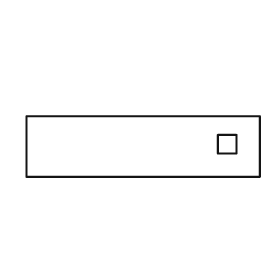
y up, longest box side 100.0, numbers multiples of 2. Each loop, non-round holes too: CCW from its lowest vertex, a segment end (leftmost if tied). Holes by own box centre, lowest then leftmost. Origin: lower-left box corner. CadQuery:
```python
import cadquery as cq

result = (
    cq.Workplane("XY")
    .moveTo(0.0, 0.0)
    .lineTo(100.0, 0.0)
    .lineTo(100.0, 26.0)
    .lineTo(0.0, 26.0)
    .close()
    .moveTo(82.0, 10.0)
    .lineTo(90.0, 10.0)
    .lineTo(90.0, 18.0)
    .lineTo(82.0, 18.0)
    .close()
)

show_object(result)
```